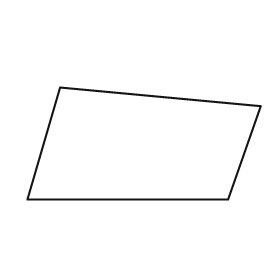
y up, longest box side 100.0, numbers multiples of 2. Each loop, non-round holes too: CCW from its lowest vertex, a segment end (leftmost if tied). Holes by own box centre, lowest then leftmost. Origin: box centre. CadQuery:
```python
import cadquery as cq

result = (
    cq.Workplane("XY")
    .moveTo(-50.0, -24.0)
    .lineTo(36.0, -24.0)
    .lineTo(50.0, 16.0)
    .lineTo(-36.0, 24.0)
    .close()
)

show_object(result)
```